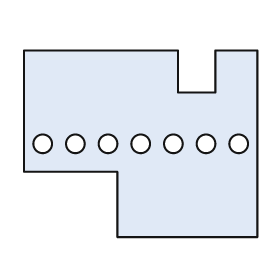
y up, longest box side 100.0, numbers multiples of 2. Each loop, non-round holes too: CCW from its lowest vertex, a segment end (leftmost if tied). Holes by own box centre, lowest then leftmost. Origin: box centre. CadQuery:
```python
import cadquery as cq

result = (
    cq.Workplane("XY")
    .moveTo(-10.0, -40.0)
    .lineTo(50.0, -40.0)
    .lineTo(50.0, 40.0)
    .lineTo(32.0, 40.0)
    .lineTo(32.0, 22.0)
    .lineTo(16.0, 22.0)
    .lineTo(16.0, 40.0)
    .lineTo(-50.0, 40.0)
    .lineTo(-50.0, -12.0)
    .lineTo(-10.0, -12.0)
    .close()
    .moveTo(-42.0, 0.0)
    .circle(4.0)
    .moveTo(-28.0, 0.0)
    .circle(4.0)
    .moveTo(-14.0, 0.0)
    .circle(4.0)
    .moveTo(0.0, 0.0)
    .circle(4.0)
    .moveTo(14.0, 0.0)
    .circle(4.0)
    .moveTo(28.0, 0.0)
    .circle(4.0)
    .moveTo(42.0, 0.0)
    .circle(4.0)
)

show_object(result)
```